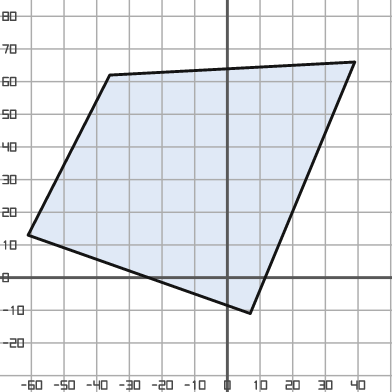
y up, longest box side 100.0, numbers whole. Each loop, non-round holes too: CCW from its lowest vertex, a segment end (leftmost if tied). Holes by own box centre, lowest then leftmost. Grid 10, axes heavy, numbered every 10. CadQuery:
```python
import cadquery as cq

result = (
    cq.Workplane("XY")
    .moveTo(7.0, -11.0)
    .lineTo(39.0, 66.0)
    .lineTo(-36.0, 62.0)
    .lineTo(-61.0, 13.0)
    .close()
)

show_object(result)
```